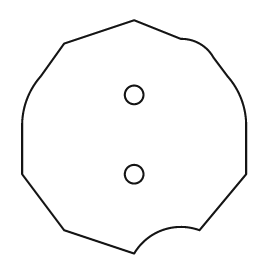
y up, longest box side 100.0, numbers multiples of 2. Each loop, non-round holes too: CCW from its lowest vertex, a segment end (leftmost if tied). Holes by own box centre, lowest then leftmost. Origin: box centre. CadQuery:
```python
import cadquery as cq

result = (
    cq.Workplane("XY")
    .moveTo(0.0, -50.0)
    .threePointArc((12.0, -40.0), (28.0, -40.0))
    .lineTo(48.0, -16.0)
    .lineTo(48.0, 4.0)
    .threePointArc((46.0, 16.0), (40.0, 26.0))
    .lineTo(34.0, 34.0)
    .threePointArc((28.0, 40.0), (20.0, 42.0))
    .lineTo(0.0, 50.0)
    .lineTo(-30.0, 40.0)
    .lineTo(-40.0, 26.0)
    .threePointArc((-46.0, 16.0), (-48.0, 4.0))
    .lineTo(-48.0, -16.0)
    .lineTo(-30.0, -40.0)
    .close()
    .moveTo(0.0, -16.0)
    .circle(4.0)
    .moveTo(0.0, 18.0)
    .circle(4.0)
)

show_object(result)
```